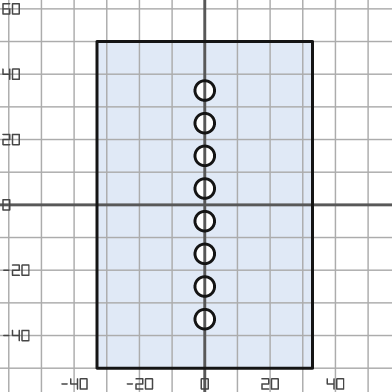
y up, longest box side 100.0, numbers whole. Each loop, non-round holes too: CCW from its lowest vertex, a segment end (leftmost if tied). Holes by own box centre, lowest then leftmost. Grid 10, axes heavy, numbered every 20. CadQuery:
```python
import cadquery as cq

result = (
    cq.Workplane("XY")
    .moveTo(-33.0, -50.0)
    .lineTo(33.0, -50.0)
    .lineTo(33.0, 50.0)
    .lineTo(-33.0, 50.0)
    .close()
    .moveTo(0.0, -35.0)
    .circle(3.0)
    .moveTo(0.0, -25.0)
    .circle(3.0)
    .moveTo(0.0, -15.0)
    .circle(3.0)
    .moveTo(0.0, -5.0)
    .circle(3.0)
    .moveTo(0.0, 5.0)
    .circle(3.0)
    .moveTo(0.0, 15.0)
    .circle(3.0)
    .moveTo(0.0, 25.0)
    .circle(3.0)
    .moveTo(0.0, 35.0)
    .circle(3.0)
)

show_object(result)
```